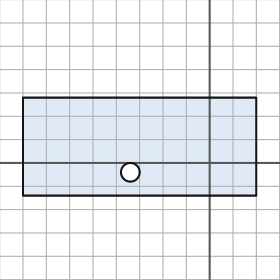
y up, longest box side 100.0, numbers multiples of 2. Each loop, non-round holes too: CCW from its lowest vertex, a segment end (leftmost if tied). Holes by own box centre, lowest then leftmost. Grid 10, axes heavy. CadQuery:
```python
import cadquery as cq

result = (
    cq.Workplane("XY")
    .moveTo(-80.0, -14.0)
    .lineTo(20.0, -14.0)
    .lineTo(20.0, 28.0)
    .lineTo(-80.0, 28.0)
    .close()
    .moveTo(-34.0, -4.0)
    .circle(4.0)
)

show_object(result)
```